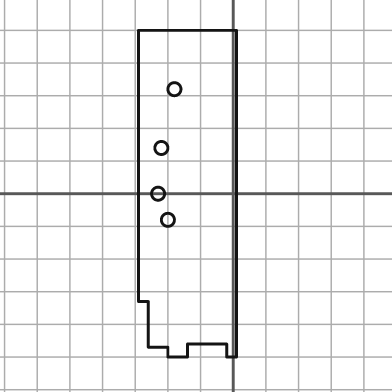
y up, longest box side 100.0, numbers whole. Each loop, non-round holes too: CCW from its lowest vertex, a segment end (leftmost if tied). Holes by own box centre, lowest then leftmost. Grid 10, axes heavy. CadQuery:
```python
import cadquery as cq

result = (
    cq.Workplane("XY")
    .moveTo(-20.0, -50.0)
    .lineTo(-14.0, -50.0)
    .lineTo(-14.0, -46.0)
    .lineTo(-2.0, -46.0)
    .lineTo(-2.0, -50.0)
    .lineTo(1.0, -50.0)
    .lineTo(1.0, 50.0)
    .lineTo(-29.0, 50.0)
    .lineTo(-29.0, -33.0)
    .lineTo(-26.0, -33.0)
    .lineTo(-26.0, -47.0)
    .lineTo(-20.0, -47.0)
    .close()
    .moveTo(-20.0, -8.0)
    .circle(2.0)
    .moveTo(-23.0, 0.0)
    .circle(2.0)
    .moveTo(-22.0, 14.0)
    .circle(2.0)
    .moveTo(-18.0, 32.0)
    .circle(2.0)
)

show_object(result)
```